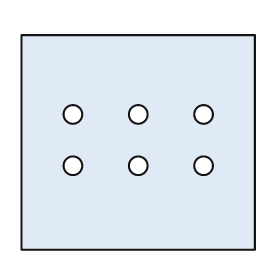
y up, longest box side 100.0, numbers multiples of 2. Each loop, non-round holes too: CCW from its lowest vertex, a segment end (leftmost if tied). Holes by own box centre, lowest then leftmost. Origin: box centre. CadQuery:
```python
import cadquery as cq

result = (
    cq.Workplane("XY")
    .moveTo(-50.0, -46.0)
    .lineTo(50.0, -46.0)
    .lineTo(50.0, 46.0)
    .lineTo(-50.0, 46.0)
    .close()
    .moveTo(-28.0, -10.0)
    .circle(4.0)
    .moveTo(0.0, -10.0)
    .circle(4.0)
    .moveTo(28.0, -10.0)
    .circle(4.0)
    .moveTo(-28.0, 12.0)
    .circle(4.0)
    .moveTo(0.0, 12.0)
    .circle(4.0)
    .moveTo(28.0, 12.0)
    .circle(4.0)
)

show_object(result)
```